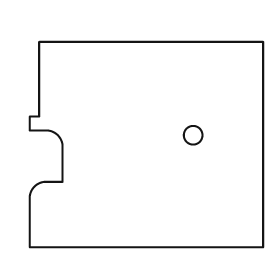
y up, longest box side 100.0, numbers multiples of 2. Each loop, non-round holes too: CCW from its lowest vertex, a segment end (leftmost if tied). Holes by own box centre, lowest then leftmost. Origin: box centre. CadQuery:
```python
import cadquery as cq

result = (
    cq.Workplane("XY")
    .moveTo(-50.0, -44.0)
    .lineTo(50.0, -44.0)
    .lineTo(50.0, 44.0)
    .lineTo(-46.0, 44.0)
    .lineTo(-46.0, 12.0)
    .lineTo(-50.0, 12.0)
    .lineTo(-50.0, 6.0)
    .lineTo(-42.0, 6.0)
    .threePointArc((-38.0, 4.0), (-36.0, 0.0))
    .lineTo(-36.0, -16.0)
    .lineTo(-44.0, -16.0)
    .threePointArc((-48.0, -18.0), (-50.0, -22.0))
    .close()
    .moveTo(20.0, 4.0)
    .circle(4.0)
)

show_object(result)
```